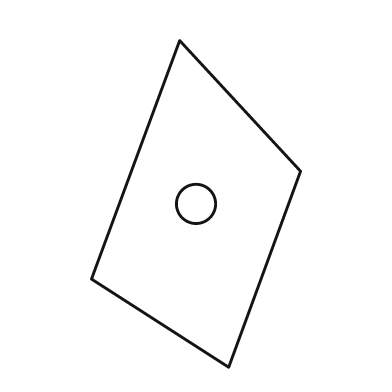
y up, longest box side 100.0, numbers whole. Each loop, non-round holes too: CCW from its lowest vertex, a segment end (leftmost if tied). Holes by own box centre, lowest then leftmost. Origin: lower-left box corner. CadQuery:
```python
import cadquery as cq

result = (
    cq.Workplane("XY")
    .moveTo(42.0, 0.0)
    .lineTo(64.0, 60.0)
    .lineTo(27.0, 100.0)
    .lineTo(0.0, 27.0)
    .close()
    .moveTo(32.0, 50.0)
    .circle(6.0)
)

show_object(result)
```